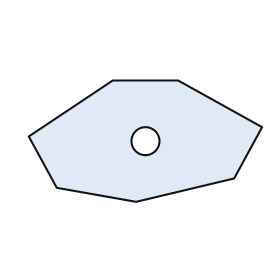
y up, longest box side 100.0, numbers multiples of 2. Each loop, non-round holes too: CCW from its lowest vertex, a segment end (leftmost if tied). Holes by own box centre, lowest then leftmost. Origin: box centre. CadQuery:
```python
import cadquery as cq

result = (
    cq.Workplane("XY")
    .moveTo(-4.0, -26.0)
    .lineTo(38.0, -16.0)
    .lineTo(50.0, 6.0)
    .lineTo(14.0, 26.0)
    .lineTo(-14.0, 26.0)
    .lineTo(-50.0, 2.0)
    .lineTo(-38.0, -20.0)
    .close()
    .moveTo(0.0, 0.0)
    .circle(6.0)
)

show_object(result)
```